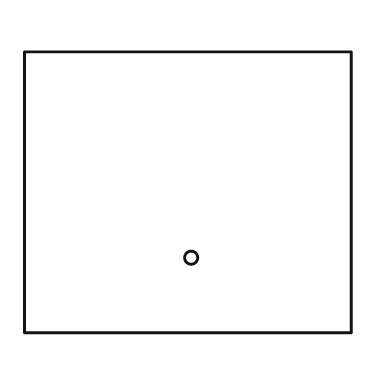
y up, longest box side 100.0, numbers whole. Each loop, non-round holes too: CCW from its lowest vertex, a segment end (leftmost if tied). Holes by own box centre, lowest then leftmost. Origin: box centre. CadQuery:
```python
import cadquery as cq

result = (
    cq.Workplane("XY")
    .moveTo(-50.0, -43.0)
    .lineTo(50.0, -43.0)
    .lineTo(50.0, 43.0)
    .lineTo(-50.0, 43.0)
    .close()
    .moveTo(1.0, -20.0)
    .circle(2.0)
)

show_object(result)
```